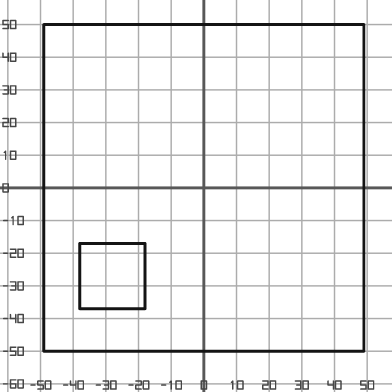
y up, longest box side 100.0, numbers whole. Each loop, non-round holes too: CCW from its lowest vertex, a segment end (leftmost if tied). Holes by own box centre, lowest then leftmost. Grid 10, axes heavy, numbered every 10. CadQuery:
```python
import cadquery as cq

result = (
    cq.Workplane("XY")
    .moveTo(-49.0, -50.0)
    .lineTo(49.0, -50.0)
    .lineTo(49.0, 50.0)
    .lineTo(-49.0, 50.0)
    .close()
    .moveTo(-38.0, -37.0)
    .lineTo(-18.0, -37.0)
    .lineTo(-18.0, -17.0)
    .lineTo(-38.0, -17.0)
    .close()
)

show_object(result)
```